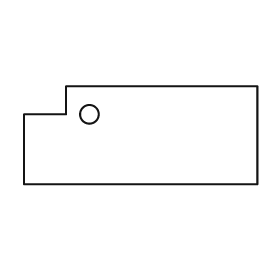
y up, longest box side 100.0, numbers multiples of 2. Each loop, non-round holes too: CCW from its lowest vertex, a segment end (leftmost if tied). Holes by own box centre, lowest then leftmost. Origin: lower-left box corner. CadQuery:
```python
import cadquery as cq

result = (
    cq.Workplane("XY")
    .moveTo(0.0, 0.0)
    .lineTo(100.0, 0.0)
    .lineTo(100.0, 42.0)
    .lineTo(18.0, 42.0)
    .lineTo(18.0, 30.0)
    .lineTo(0.0, 30.0)
    .close()
    .moveTo(28.0, 30.0)
    .circle(4.0)
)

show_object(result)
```